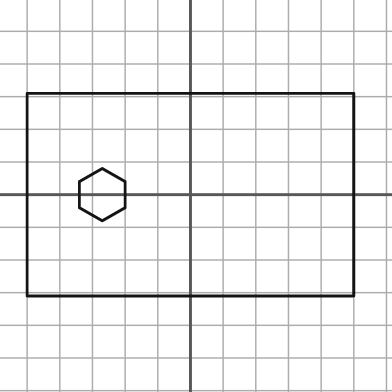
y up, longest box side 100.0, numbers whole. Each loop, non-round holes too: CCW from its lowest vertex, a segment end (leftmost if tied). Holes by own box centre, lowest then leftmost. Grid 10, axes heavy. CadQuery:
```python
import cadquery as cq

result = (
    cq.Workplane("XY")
    .moveTo(-50.0, -31.0)
    .lineTo(50.0, -31.0)
    .lineTo(50.0, 31.0)
    .lineTo(-50.0, 31.0)
    .close()
    .moveTo(-27.0, -8.0)
    .lineTo(-20.0, -4.0)
    .lineTo(-20.0, 4.0)
    .lineTo(-27.0, 8.0)
    .lineTo(-34.0, 4.0)
    .lineTo(-34.0, -4.0)
    .close()
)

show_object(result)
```